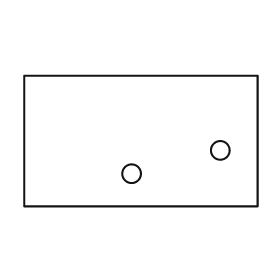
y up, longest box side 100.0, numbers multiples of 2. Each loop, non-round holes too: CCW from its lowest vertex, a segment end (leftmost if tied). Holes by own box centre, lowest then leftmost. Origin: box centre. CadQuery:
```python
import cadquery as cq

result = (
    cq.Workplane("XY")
    .moveTo(-50.0, -28.0)
    .lineTo(50.0, -28.0)
    .lineTo(50.0, 28.0)
    .lineTo(-50.0, 28.0)
    .close()
    .moveTo(-4.0, -14.0)
    .circle(4.0)
    .moveTo(34.0, -4.0)
    .circle(4.0)
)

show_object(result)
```